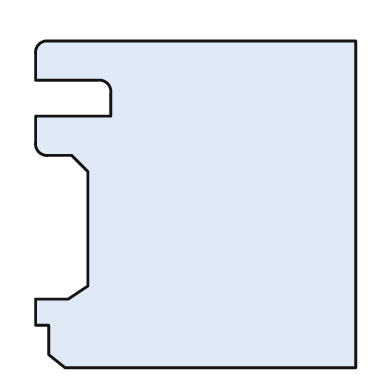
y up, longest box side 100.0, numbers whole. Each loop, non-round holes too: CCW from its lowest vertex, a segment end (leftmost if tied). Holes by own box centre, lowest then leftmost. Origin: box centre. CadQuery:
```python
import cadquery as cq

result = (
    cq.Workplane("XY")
    .moveTo(-40.0, -50.0)
    .lineTo(49.0, -50.0)
    .lineTo(49.0, 50.0)
    .lineTo(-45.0, 50.0)
    .threePointArc((-48.0, 49.0), (-49.0, 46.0))
    .lineTo(-49.0, 38.0)
    .lineTo(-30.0, 38.0)
    .threePointArc((-27.0, 37.0), (-26.0, 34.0))
    .lineTo(-26.0, 27.0)
    .lineTo(-49.0, 27.0)
    .lineTo(-49.0, 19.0)
    .threePointArc((-48.0, 16.0), (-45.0, 15.0))
    .lineTo(-38.0, 15.0)
    .lineTo(-33.0, 10.0)
    .lineTo(-33.0, -25.0)
    .lineTo(-39.0, -29.0)
    .lineTo(-49.0, -29.0)
    .lineTo(-49.0, -37.0)
    .lineTo(-45.0, -37.0)
    .lineTo(-45.0, -46.0)
    .close()
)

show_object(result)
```